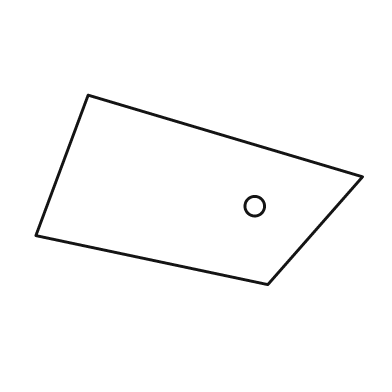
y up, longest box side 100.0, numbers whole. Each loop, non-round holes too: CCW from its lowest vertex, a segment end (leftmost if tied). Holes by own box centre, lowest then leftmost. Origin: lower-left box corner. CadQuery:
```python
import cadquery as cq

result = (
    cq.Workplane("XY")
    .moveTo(71.0, 0.0)
    .lineTo(100.0, 33.0)
    .lineTo(16.0, 58.0)
    .lineTo(0.0, 15.0)
    .close()
    .moveTo(67.0, 24.0)
    .circle(3.0)
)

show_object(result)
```